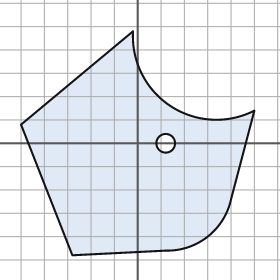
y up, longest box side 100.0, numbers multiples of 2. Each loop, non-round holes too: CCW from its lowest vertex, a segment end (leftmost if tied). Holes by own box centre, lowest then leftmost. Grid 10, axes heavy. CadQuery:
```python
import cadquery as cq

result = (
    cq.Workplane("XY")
    .moveTo(-28.0, -48.0)
    .lineTo(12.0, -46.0)
    .threePointArc((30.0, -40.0), (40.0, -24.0))
    .lineTo(50.0, 14.0)
    .threePointArc((14.0, 16.0), (-2.0, 48.0))
    .lineTo(-50.0, 8.0)
    .close()
    .moveTo(12.0, 0.0)
    .circle(4.0)
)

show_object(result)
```